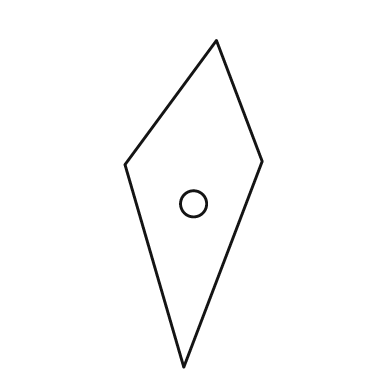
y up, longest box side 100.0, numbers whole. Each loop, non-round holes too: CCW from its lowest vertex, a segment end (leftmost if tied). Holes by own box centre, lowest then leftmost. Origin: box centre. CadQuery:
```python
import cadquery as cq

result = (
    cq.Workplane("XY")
    .moveTo(-3.0, -50.0)
    .lineTo(21.0, 13.0)
    .lineTo(7.0, 50.0)
    .lineTo(-21.0, 12.0)
    .close()
    .moveTo(0.0, 0.0)
    .circle(4.0)
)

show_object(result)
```